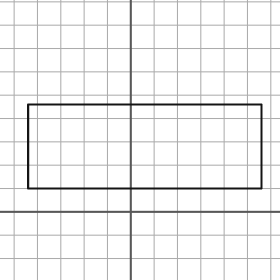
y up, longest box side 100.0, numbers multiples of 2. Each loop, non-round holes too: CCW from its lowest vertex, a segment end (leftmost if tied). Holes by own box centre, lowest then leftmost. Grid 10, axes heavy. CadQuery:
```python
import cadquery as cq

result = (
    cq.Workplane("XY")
    .moveTo(-44.0, 10.0)
    .lineTo(56.0, 10.0)
    .lineTo(56.0, 46.0)
    .lineTo(-44.0, 46.0)
    .close()
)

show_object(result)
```